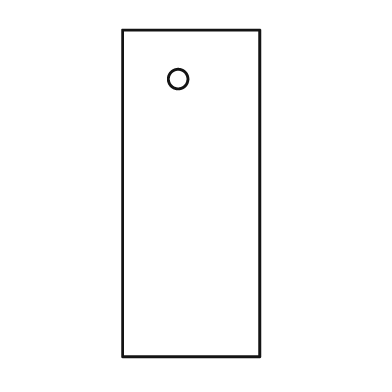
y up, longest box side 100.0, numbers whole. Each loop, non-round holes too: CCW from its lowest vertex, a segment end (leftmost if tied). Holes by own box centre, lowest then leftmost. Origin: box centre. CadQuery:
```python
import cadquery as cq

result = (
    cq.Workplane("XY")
    .moveTo(-21.0, -50.0)
    .lineTo(21.0, -50.0)
    .lineTo(21.0, 50.0)
    .lineTo(-21.0, 50.0)
    .close()
    .moveTo(-4.0, 35.0)
    .circle(3.0)
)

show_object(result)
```